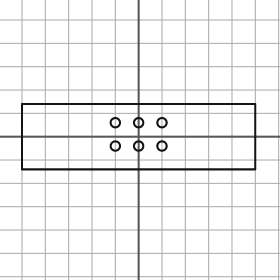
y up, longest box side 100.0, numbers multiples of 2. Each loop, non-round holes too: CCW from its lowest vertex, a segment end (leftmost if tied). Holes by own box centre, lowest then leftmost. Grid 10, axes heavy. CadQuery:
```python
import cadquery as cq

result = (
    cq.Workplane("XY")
    .moveTo(-50.0, -14.0)
    .lineTo(50.0, -14.0)
    .lineTo(50.0, 14.0)
    .lineTo(-50.0, 14.0)
    .close()
    .moveTo(-10.0, -4.0)
    .circle(2.0)
    .moveTo(0.0, -4.0)
    .circle(2.0)
    .moveTo(10.0, -4.0)
    .circle(2.0)
    .moveTo(-10.0, 6.0)
    .circle(2.0)
    .moveTo(0.0, 6.0)
    .circle(2.0)
    .moveTo(10.0, 6.0)
    .circle(2.0)
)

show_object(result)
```